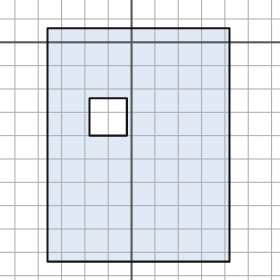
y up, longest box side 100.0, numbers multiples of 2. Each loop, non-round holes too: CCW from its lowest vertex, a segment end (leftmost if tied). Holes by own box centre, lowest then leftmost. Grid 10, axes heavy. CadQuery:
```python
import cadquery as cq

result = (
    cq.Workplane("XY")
    .moveTo(-36.0, -94.0)
    .lineTo(42.0, -94.0)
    .lineTo(42.0, 6.0)
    .lineTo(-36.0, 6.0)
    .close()
    .moveTo(-18.0, -40.0)
    .lineTo(-2.0, -40.0)
    .lineTo(-2.0, -24.0)
    .lineTo(-18.0, -24.0)
    .close()
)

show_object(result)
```